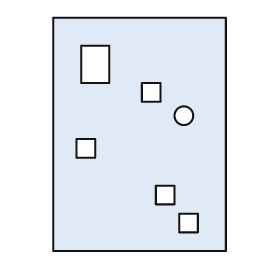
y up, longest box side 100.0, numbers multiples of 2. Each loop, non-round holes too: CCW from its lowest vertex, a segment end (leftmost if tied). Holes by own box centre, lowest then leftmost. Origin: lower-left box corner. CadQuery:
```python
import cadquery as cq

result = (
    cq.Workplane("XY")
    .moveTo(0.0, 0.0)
    .lineTo(74.0, 0.0)
    .lineTo(74.0, 100.0)
    .lineTo(0.0, 100.0)
    .close()
    .moveTo(54.0, 8.0)
    .lineTo(62.0, 8.0)
    .lineTo(62.0, 16.0)
    .lineTo(54.0, 16.0)
    .close()
    .moveTo(44.0, 20.0)
    .lineTo(52.0, 20.0)
    .lineTo(52.0, 28.0)
    .lineTo(44.0, 28.0)
    .close()
    .moveTo(10.0, 40.0)
    .lineTo(18.0, 40.0)
    .lineTo(18.0, 48.0)
    .lineTo(10.0, 48.0)
    .close()
    .moveTo(56.0, 58.0)
    .circle(4.0)
    .moveTo(38.0, 64.0)
    .lineTo(46.0, 64.0)
    .lineTo(46.0, 72.0)
    .lineTo(38.0, 72.0)
    .close()
    .moveTo(12.0, 72.0)
    .lineTo(24.0, 72.0)
    .lineTo(24.0, 88.0)
    .lineTo(12.0, 88.0)
    .close()
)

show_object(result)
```